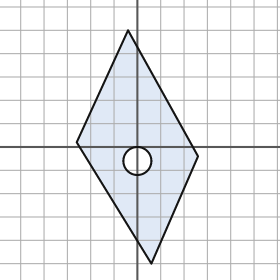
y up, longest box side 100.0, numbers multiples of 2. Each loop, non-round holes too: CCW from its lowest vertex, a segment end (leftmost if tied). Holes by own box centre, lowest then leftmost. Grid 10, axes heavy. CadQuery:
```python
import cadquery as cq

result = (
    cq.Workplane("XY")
    .moveTo(6.0, -50.0)
    .lineTo(26.0, -4.0)
    .lineTo(-4.0, 50.0)
    .lineTo(-26.0, 2.0)
    .close()
    .moveTo(0.0, -6.0)
    .circle(6.0)
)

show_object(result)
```